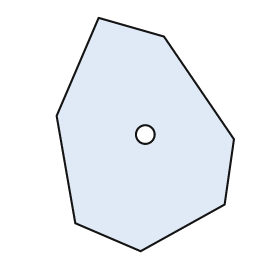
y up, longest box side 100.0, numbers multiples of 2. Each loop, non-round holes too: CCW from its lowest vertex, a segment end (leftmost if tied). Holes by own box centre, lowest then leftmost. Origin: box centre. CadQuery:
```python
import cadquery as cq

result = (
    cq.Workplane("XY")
    .moveTo(-2.0, -50.0)
    .lineTo(34.0, -30.0)
    .lineTo(38.0, -2.0)
    .lineTo(8.0, 42.0)
    .lineTo(-20.0, 50.0)
    .lineTo(-38.0, 8.0)
    .lineTo(-30.0, -38.0)
    .close()
    .moveTo(0.0, 0.0)
    .circle(4.0)
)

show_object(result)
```